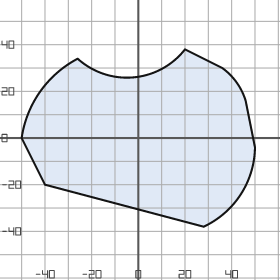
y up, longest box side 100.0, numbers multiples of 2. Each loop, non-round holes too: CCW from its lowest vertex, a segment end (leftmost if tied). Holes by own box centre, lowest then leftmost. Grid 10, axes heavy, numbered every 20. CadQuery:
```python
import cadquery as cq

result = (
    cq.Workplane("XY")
    .moveTo(28.0, -38.0)
    .threePointArc((44.0, -24.0), (50.0, -4.0))
    .lineTo(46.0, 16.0)
    .threePointArc((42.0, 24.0), (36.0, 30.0))
    .lineTo(20.0, 38.0)
    .threePointArc((-2.0, 26.0), (-26.0, 34.0))
    .threePointArc((-42.0, 20.0), (-50.0, 0.0))
    .lineTo(-40.0, -20.0)
    .close()
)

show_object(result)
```